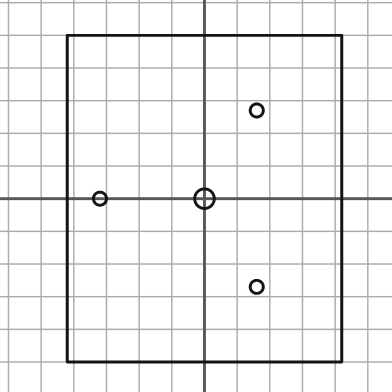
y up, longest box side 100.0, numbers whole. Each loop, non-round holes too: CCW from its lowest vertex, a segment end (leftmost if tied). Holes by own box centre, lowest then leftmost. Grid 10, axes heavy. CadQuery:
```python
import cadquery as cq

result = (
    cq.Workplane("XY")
    .moveTo(-42.0, -50.0)
    .lineTo(42.0, -50.0)
    .lineTo(42.0, 50.0)
    .lineTo(-42.0, 50.0)
    .close()
    .moveTo(16.0, -27.0)
    .circle(2.0)
    .moveTo(-32.0, 0.0)
    .circle(2.0)
    .moveTo(0.0, 0.0)
    .circle(3.0)
    .moveTo(16.0, 27.0)
    .circle(2.0)
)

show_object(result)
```